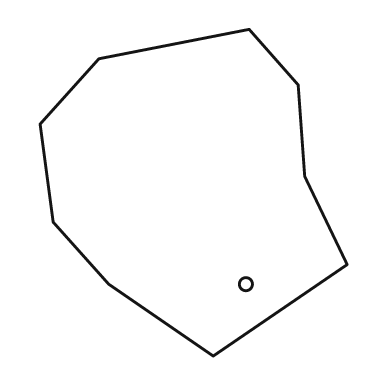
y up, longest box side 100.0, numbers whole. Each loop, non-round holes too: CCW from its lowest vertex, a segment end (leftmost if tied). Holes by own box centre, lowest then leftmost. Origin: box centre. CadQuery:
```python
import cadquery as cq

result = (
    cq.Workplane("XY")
    .moveTo(6.0, -50.0)
    .lineTo(47.0, -22.0)
    .lineTo(34.0, 5.0)
    .lineTo(32.0, 33.0)
    .lineTo(17.0, 50.0)
    .lineTo(-29.0, 41.0)
    .lineTo(-47.0, 21.0)
    .lineTo(-43.0, -9.0)
    .lineTo(-26.0, -28.0)
    .close()
    .moveTo(16.0, -28.0)
    .circle(2.0)
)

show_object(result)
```